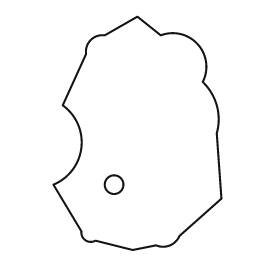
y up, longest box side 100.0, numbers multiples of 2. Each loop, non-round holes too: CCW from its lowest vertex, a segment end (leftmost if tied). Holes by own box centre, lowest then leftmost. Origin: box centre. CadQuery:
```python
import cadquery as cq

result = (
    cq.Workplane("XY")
    .moveTo(-2.0, -50.0)
    .lineTo(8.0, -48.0)
    .threePointArc((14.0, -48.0), (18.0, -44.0))
    .lineTo(36.0, -28.0)
    .lineTo(34.0, 0.0)
    .threePointArc((34.0, 12.0), (28.0, 22.0))
    .threePointArc((26.0, 38.0), (10.0, 42.0))
    .lineTo(0.0, 50.0)
    .lineTo(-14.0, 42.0)
    .threePointArc((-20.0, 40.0), (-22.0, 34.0))
    .lineTo(-32.0, 12.0)
    .threePointArc((-24.0, -6.0), (-36.0, -22.0))
    .lineTo(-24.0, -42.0)
    .threePointArc((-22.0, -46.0), (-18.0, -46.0))
    .close()
    .moveTo(-10.0, -22.0)
    .circle(4.0)
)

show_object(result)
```